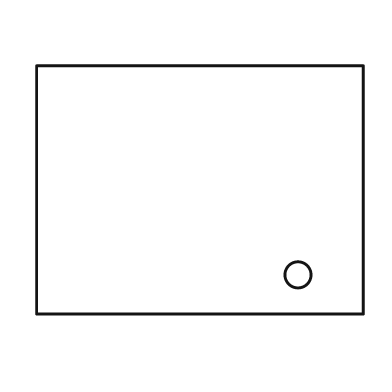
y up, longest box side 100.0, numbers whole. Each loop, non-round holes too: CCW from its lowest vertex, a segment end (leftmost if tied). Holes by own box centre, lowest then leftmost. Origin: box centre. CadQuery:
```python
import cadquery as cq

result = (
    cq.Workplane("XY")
    .moveTo(-50.0, -38.0)
    .lineTo(50.0, -38.0)
    .lineTo(50.0, 38.0)
    .lineTo(-50.0, 38.0)
    .close()
    .moveTo(30.0, -26.0)
    .circle(4.0)
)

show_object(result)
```